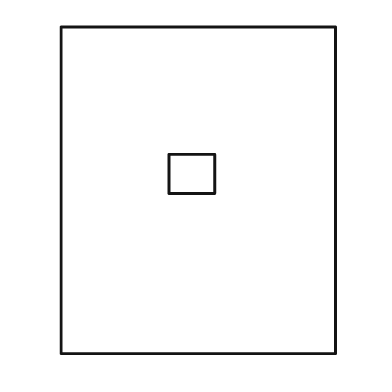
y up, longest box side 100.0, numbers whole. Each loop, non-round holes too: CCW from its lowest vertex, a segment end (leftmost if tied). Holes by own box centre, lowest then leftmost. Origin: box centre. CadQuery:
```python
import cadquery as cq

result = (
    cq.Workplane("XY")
    .moveTo(-42.0, -50.0)
    .lineTo(42.0, -50.0)
    .lineTo(42.0, 50.0)
    .lineTo(-42.0, 50.0)
    .close()
    .moveTo(-9.0, -1.0)
    .lineTo(5.0, -1.0)
    .lineTo(5.0, 11.0)
    .lineTo(-9.0, 11.0)
    .close()
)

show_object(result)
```